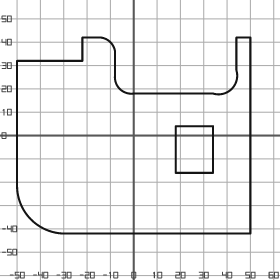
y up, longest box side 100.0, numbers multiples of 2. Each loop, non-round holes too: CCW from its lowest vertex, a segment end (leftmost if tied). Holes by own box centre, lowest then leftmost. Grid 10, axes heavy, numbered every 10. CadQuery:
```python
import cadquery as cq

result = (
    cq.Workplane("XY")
    .moveTo(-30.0, -42.0)
    .lineTo(50.0, -42.0)
    .lineTo(50.0, 42.0)
    .lineTo(44.0, 42.0)
    .lineTo(44.0, 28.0)
    .threePointArc((42.0, 20.0), (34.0, 18.0))
    .lineTo(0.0, 18.0)
    .threePointArc((-6.0, 20.0), (-8.0, 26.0))
    .lineTo(-8.0, 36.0)
    .threePointArc((-10.0, 40.0), (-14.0, 42.0))
    .lineTo(-22.0, 42.0)
    .lineTo(-22.0, 32.0)
    .lineTo(-50.0, 32.0)
    .lineTo(-50.0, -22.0)
    .threePointArc((-44.0, -36.0), (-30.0, -42.0))
    .close()
    .moveTo(18.0, -16.0)
    .lineTo(34.0, -16.0)
    .lineTo(34.0, 4.0)
    .lineTo(18.0, 4.0)
    .close()
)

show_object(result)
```